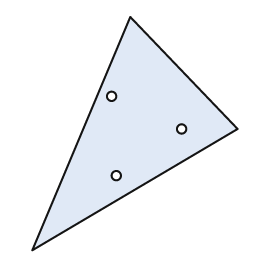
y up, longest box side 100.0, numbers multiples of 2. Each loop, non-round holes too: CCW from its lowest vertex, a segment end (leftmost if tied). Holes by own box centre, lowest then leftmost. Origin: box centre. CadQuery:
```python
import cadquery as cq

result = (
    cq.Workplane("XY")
    .moveTo(-44.0, -50.0)
    .lineTo(44.0, 2.0)
    .lineTo(-2.0, 50.0)
    .close()
    .moveTo(-8.0, -18.0)
    .circle(2.0)
    .moveTo(20.0, 2.0)
    .circle(2.0)
    .moveTo(-10.0, 16.0)
    .circle(2.0)
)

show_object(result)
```